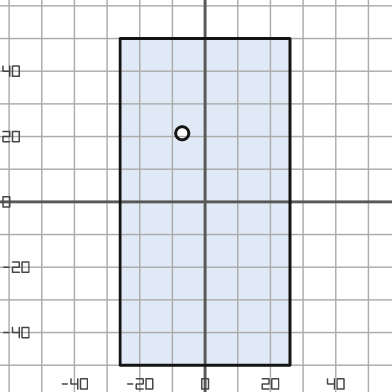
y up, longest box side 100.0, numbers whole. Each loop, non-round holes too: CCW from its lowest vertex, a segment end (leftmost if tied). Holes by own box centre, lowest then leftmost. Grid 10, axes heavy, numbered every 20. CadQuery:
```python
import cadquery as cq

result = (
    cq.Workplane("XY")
    .moveTo(-26.0, -50.0)
    .lineTo(26.0, -50.0)
    .lineTo(26.0, 50.0)
    .lineTo(-26.0, 50.0)
    .close()
    .moveTo(-7.0, 21.0)
    .circle(2.0)
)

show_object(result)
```